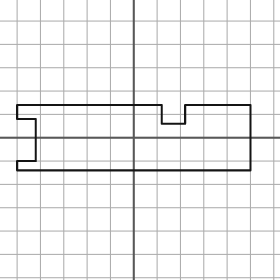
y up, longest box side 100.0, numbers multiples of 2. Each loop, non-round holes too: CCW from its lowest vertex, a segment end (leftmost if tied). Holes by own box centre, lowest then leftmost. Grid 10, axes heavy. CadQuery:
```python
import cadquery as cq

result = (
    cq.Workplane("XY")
    .moveTo(-50.0, -14.0)
    .lineTo(50.0, -14.0)
    .lineTo(50.0, 14.0)
    .lineTo(22.0, 14.0)
    .lineTo(22.0, 6.0)
    .lineTo(12.0, 6.0)
    .lineTo(12.0, 14.0)
    .lineTo(-50.0, 14.0)
    .lineTo(-50.0, 8.0)
    .lineTo(-42.0, 8.0)
    .lineTo(-42.0, -10.0)
    .lineTo(-50.0, -10.0)
    .close()
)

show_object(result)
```